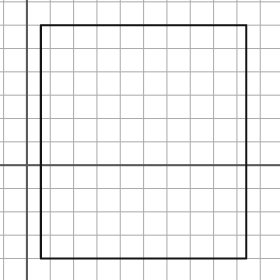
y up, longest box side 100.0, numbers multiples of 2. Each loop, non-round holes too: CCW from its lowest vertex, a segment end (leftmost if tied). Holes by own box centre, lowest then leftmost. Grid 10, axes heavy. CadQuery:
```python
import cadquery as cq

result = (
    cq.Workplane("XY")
    .moveTo(6.0, -40.0)
    .lineTo(94.0, -40.0)
    .lineTo(94.0, 60.0)
    .lineTo(6.0, 60.0)
    .close()
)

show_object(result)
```